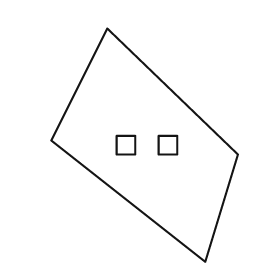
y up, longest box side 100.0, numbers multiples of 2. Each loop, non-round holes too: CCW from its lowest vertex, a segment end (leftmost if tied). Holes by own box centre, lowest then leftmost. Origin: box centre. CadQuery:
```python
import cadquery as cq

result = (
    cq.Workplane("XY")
    .moveTo(26.0, -50.0)
    .lineTo(40.0, -4.0)
    .lineTo(-16.0, 50.0)
    .lineTo(-40.0, 2.0)
    .close()
    .moveTo(-12.0, -4.0)
    .lineTo(-4.0, -4.0)
    .lineTo(-4.0, 4.0)
    .lineTo(-12.0, 4.0)
    .close()
    .moveTo(6.0, -4.0)
    .lineTo(14.0, -4.0)
    .lineTo(14.0, 4.0)
    .lineTo(6.0, 4.0)
    .close()
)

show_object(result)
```